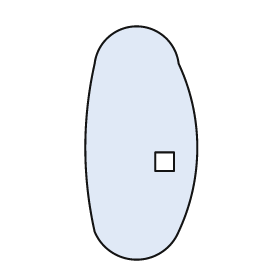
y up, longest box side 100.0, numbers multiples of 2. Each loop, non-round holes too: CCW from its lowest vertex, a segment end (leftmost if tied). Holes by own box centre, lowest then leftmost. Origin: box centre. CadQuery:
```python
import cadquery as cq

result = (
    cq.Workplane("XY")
    .moveTo(-20.0, -38.0)
    .threePointArc((-2.0, -50.0), (16.0, -38.0))
    .threePointArc((24.0, -2.0), (16.0, 34.0))
    .threePointArc((-2.0, 50.0), (-20.0, 34.0))
    .threePointArc((-24.0, -2.0), (-20.0, -38.0))
    .close()
    .moveTo(6.0, -12.0)
    .lineTo(14.0, -12.0)
    .lineTo(14.0, -4.0)
    .lineTo(6.0, -4.0)
    .close()
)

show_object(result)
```